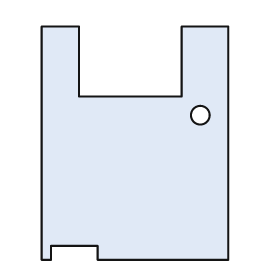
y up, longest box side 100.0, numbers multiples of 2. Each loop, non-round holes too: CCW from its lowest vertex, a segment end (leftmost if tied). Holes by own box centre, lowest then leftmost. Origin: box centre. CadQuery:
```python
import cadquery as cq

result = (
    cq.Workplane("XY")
    .moveTo(-40.0, -50.0)
    .lineTo(-36.0, -50.0)
    .lineTo(-36.0, -44.0)
    .lineTo(-16.0, -44.0)
    .lineTo(-16.0, -50.0)
    .lineTo(40.0, -50.0)
    .lineTo(40.0, 50.0)
    .lineTo(20.0, 50.0)
    .lineTo(20.0, 20.0)
    .lineTo(-24.0, 20.0)
    .lineTo(-24.0, 50.0)
    .lineTo(-40.0, 50.0)
    .close()
    .moveTo(28.0, 12.0)
    .circle(4.0)
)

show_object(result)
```